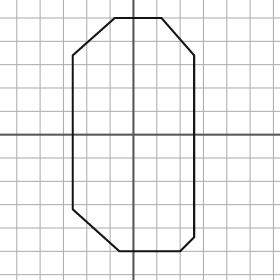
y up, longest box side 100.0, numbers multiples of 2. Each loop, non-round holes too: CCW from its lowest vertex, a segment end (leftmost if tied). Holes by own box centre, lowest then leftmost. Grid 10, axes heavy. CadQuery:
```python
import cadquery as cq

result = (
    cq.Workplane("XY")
    .moveTo(-6.0, -50.0)
    .lineTo(20.0, -50.0)
    .lineTo(26.0, -44.0)
    .lineTo(26.0, 34.0)
    .lineTo(12.0, 50.0)
    .lineTo(-8.0, 50.0)
    .lineTo(-26.0, 34.0)
    .lineTo(-26.0, -32.0)
    .close()
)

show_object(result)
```